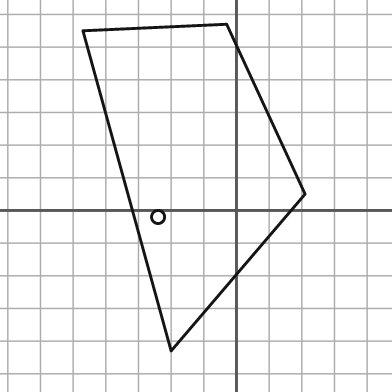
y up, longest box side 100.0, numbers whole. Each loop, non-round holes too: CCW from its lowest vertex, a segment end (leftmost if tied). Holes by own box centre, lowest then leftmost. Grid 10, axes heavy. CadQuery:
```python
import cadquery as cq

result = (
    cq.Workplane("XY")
    .moveTo(-20.0, -43.0)
    .lineTo(21.0, 5.0)
    .lineTo(-3.0, 57.0)
    .lineTo(-47.0, 55.0)
    .close()
    .moveTo(-24.0, -2.0)
    .circle(2.0)
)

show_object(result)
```